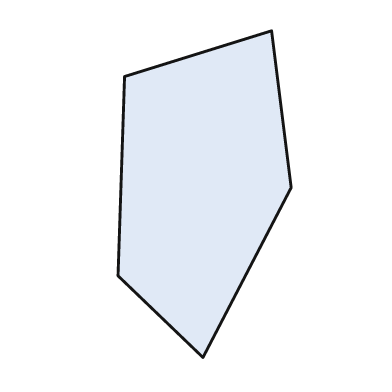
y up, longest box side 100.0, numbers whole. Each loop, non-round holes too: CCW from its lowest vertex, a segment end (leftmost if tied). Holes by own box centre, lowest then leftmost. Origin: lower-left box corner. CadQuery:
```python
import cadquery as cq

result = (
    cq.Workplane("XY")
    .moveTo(26.0, 0.0)
    .lineTo(53.0, 52.0)
    .lineTo(47.0, 100.0)
    .lineTo(2.0, 86.0)
    .lineTo(0.0, 25.0)
    .close()
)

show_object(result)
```